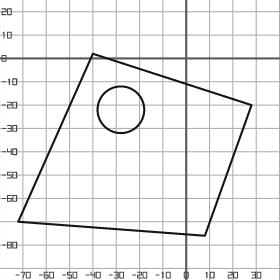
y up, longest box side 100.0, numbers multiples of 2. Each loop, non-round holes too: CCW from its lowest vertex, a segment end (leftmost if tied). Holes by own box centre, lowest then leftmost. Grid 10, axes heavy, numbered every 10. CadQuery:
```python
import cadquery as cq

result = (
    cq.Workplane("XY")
    .moveTo(8.0, -76.0)
    .lineTo(28.0, -20.0)
    .lineTo(-40.0, 2.0)
    .lineTo(-72.0, -70.0)
    .close()
    .moveTo(-28.0, -22.0)
    .circle(10.0)
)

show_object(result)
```